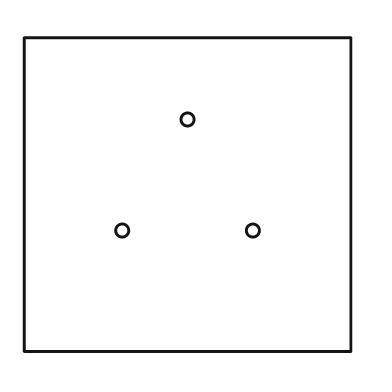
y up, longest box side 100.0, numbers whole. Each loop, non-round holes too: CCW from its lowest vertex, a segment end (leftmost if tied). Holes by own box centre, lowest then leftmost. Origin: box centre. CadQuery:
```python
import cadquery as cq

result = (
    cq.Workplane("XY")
    .moveTo(-50.0, -48.0)
    .lineTo(50.0, -48.0)
    .lineTo(50.0, 48.0)
    .lineTo(-50.0, 48.0)
    .close()
    .moveTo(-20.0, -11.0)
    .circle(2.0)
    .moveTo(20.0, -11.0)
    .circle(2.0)
    .moveTo(0.0, 23.0)
    .circle(2.0)
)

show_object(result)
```